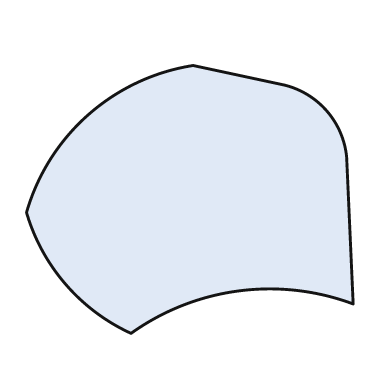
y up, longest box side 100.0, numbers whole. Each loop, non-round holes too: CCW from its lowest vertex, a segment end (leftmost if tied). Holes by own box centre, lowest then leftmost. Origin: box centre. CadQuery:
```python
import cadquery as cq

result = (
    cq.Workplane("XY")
    .moveTo(-18.0, -41.0)
    .threePointArc((15.0, -28.0), (50.0, -32.0))
    .lineTo(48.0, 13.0)
    .threePointArc((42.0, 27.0), (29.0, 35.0))
    .lineTo(1.0, 41.0)
    .threePointArc((-31.0, 26.0), (-50.0, -4.0))
    .threePointArc((-38.0, -26.0), (-18.0, -41.0))
    .close()
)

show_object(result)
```